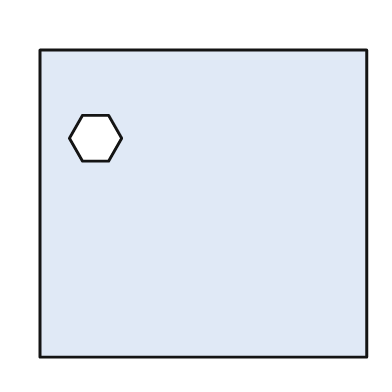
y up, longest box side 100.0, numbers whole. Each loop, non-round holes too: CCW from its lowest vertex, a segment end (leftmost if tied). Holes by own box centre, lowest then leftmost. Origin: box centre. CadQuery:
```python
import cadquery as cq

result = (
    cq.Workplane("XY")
    .moveTo(-50.0, -47.0)
    .lineTo(50.0, -47.0)
    .lineTo(50.0, 47.0)
    .lineTo(-50.0, 47.0)
    .close()
    .moveTo(-37.0, 13.0)
    .lineTo(-29.0, 13.0)
    .lineTo(-25.0, 20.0)
    .lineTo(-29.0, 27.0)
    .lineTo(-37.0, 27.0)
    .lineTo(-41.0, 20.0)
    .close()
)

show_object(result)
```